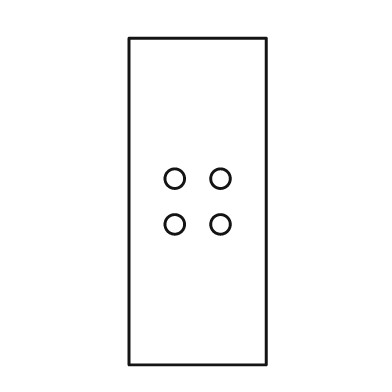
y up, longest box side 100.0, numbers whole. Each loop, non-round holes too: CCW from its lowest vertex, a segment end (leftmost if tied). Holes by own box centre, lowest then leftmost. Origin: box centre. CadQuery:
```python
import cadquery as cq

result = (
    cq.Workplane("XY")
    .moveTo(-21.0, -50.0)
    .lineTo(21.0, -50.0)
    .lineTo(21.0, 50.0)
    .lineTo(-21.0, 50.0)
    .close()
    .moveTo(-7.0, -7.0)
    .circle(3.0)
    .moveTo(7.0, -7.0)
    .circle(3.0)
    .moveTo(-7.0, 7.0)
    .circle(3.0)
    .moveTo(7.0, 7.0)
    .circle(3.0)
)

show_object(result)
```